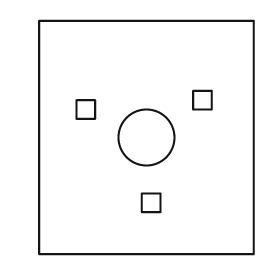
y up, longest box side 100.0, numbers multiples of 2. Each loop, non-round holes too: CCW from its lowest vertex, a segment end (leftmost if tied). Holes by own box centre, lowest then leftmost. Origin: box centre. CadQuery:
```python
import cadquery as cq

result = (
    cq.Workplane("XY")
    .moveTo(-46.0, -50.0)
    .lineTo(46.0, -50.0)
    .lineTo(46.0, 50.0)
    .lineTo(-46.0, 50.0)
    .close()
    .moveTo(-2.0, -32.0)
    .lineTo(6.0, -32.0)
    .lineTo(6.0, -24.0)
    .lineTo(-2.0, -24.0)
    .close()
    .moveTo(0.0, 0.0)
    .circle(12.0)
    .moveTo(-30.0, 8.0)
    .lineTo(-22.0, 8.0)
    .lineTo(-22.0, 16.0)
    .lineTo(-30.0, 16.0)
    .close()
    .moveTo(20.0, 12.0)
    .lineTo(28.0, 12.0)
    .lineTo(28.0, 20.0)
    .lineTo(20.0, 20.0)
    .close()
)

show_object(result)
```